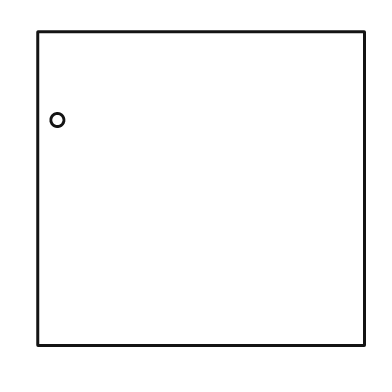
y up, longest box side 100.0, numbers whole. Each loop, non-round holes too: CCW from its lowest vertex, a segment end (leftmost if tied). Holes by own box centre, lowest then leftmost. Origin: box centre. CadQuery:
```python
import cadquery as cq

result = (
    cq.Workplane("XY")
    .moveTo(-50.0, -48.0)
    .lineTo(50.0, -48.0)
    .lineTo(50.0, 48.0)
    .lineTo(-50.0, 48.0)
    .close()
    .moveTo(-44.0, 21.0)
    .circle(2.0)
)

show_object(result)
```